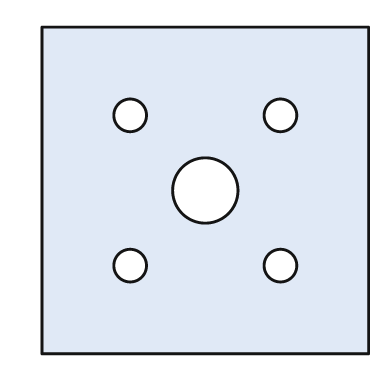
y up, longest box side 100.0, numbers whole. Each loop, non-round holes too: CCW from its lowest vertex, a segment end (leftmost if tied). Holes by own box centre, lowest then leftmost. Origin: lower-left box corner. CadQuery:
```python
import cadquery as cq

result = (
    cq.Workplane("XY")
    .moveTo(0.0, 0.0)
    .lineTo(100.0, 0.0)
    .lineTo(100.0, 100.0)
    .lineTo(0.0, 100.0)
    .close()
    .moveTo(27.0, 27.0)
    .circle(5.0)
    .moveTo(73.0, 27.0)
    .circle(5.0)
    .moveTo(50.0, 50.0)
    .circle(10.0)
    .moveTo(27.0, 73.0)
    .circle(5.0)
    .moveTo(73.0, 73.0)
    .circle(5.0)
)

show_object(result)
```